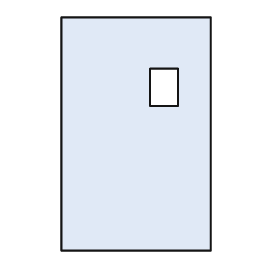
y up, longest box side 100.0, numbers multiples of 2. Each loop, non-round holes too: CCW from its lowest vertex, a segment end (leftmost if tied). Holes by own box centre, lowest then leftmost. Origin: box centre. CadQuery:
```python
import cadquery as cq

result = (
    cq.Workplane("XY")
    .moveTo(-32.0, -50.0)
    .lineTo(32.0, -50.0)
    .lineTo(32.0, 50.0)
    .lineTo(-32.0, 50.0)
    .close()
    .moveTo(6.0, 12.0)
    .lineTo(18.0, 12.0)
    .lineTo(18.0, 28.0)
    .lineTo(6.0, 28.0)
    .close()
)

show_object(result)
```